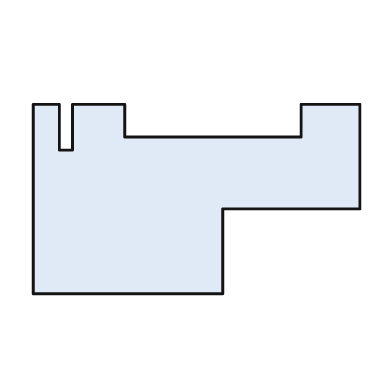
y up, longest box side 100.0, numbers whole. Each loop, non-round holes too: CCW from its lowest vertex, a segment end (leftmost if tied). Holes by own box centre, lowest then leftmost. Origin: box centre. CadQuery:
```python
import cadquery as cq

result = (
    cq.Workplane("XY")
    .moveTo(-50.0, -29.0)
    .lineTo(8.0, -29.0)
    .lineTo(8.0, -3.0)
    .lineTo(50.0, -3.0)
    .lineTo(50.0, 29.0)
    .lineTo(32.0, 29.0)
    .lineTo(32.0, 19.0)
    .lineTo(-22.0, 19.0)
    .lineTo(-22.0, 29.0)
    .lineTo(-38.0, 29.0)
    .lineTo(-38.0, 15.0)
    .lineTo(-42.0, 15.0)
    .lineTo(-42.0, 29.0)
    .lineTo(-50.0, 29.0)
    .close()
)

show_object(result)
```